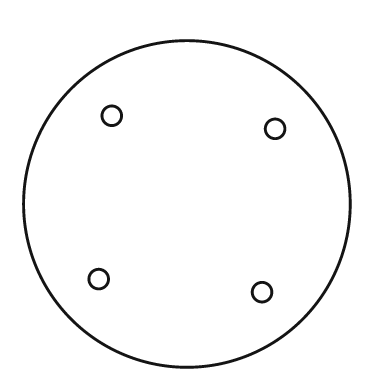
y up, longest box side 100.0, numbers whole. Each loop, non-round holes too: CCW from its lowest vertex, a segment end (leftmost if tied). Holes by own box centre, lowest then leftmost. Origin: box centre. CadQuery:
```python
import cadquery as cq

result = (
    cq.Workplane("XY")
    .moveTo(0.0, 0.0)
    .circle(50.0)
    .moveTo(23.0, -27.0)
    .circle(3.0)
    .moveTo(-27.0, -23.0)
    .circle(3.0)
    .moveTo(27.0, 23.0)
    .circle(3.0)
    .moveTo(-23.0, 27.0)
    .circle(3.0)
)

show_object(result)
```